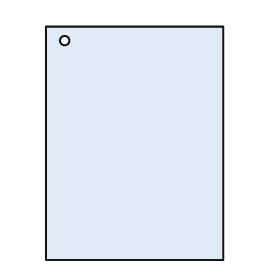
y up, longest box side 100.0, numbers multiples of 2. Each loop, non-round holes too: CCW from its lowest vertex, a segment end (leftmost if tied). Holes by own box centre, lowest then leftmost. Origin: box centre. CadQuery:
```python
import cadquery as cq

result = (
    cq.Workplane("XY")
    .moveTo(-38.0, -50.0)
    .lineTo(38.0, -50.0)
    .lineTo(38.0, 50.0)
    .lineTo(-38.0, 50.0)
    .close()
    .moveTo(-30.0, 44.0)
    .circle(2.0)
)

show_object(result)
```